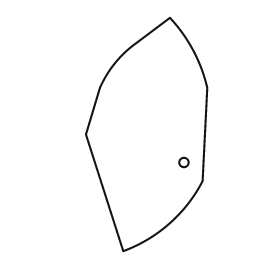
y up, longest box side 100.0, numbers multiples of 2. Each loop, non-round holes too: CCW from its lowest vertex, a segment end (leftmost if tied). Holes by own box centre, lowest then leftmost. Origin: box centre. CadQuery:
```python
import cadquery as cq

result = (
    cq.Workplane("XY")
    .moveTo(-10.0, -50.0)
    .threePointArc((10.0, -38.0), (24.0, -20.0))
    .lineTo(26.0, 20.0)
    .threePointArc((20.0, 36.0), (10.0, 50.0))
    .lineTo(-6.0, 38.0)
    .threePointArc((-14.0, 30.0), (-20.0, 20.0))
    .lineTo(-26.0, 0.0)
    .close()
    .moveTo(16.0, -12.0)
    .circle(2.0)
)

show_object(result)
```